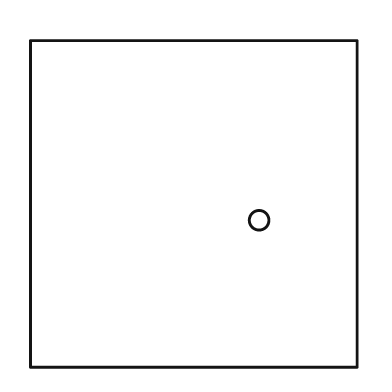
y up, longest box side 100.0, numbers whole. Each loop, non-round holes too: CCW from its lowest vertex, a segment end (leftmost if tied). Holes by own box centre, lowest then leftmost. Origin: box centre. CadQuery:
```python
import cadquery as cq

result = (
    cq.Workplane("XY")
    .moveTo(-50.0, -50.0)
    .lineTo(50.0, -50.0)
    .lineTo(50.0, 50.0)
    .lineTo(-50.0, 50.0)
    .close()
    .moveTo(20.0, -5.0)
    .circle(3.0)
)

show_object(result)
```